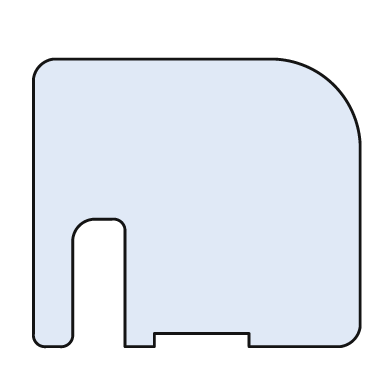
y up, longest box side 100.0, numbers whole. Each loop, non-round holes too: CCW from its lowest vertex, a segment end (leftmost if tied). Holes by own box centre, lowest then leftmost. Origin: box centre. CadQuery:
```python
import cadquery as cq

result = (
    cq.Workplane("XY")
    .moveTo(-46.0, -44.0)
    .lineTo(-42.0, -44.0)
    .threePointArc((-39.0, -43.0), (-38.0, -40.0))
    .lineTo(-38.0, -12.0)
    .threePointArc((-36.0, -7.0), (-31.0, -5.0))
    .lineTo(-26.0, -5.0)
    .threePointArc((-23.0, -6.0), (-22.0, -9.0))
    .lineTo(-22.0, -44.0)
    .lineTo(-13.0, -44.0)
    .lineTo(-13.0, -40.0)
    .lineTo(16.0, -40.0)
    .lineTo(16.0, -44.0)
    .lineTo(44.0, -44.0)
    .threePointArc((48.0, -42.0), (50.0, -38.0))
    .lineTo(50.0, 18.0)
    .threePointArc((42.0, 36.0), (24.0, 44.0))
    .lineTo(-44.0, 44.0)
    .threePointArc((-48.0, 42.0), (-50.0, 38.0))
    .lineTo(-50.0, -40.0)
    .threePointArc((-49.0, -43.0), (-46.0, -44.0))
    .close()
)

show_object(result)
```